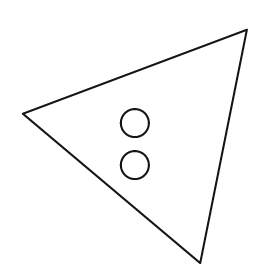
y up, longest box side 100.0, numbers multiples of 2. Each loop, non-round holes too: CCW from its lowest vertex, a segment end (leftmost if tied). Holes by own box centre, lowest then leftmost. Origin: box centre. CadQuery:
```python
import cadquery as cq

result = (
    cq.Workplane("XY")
    .moveTo(28.0, -50.0)
    .lineTo(48.0, 50.0)
    .lineTo(-48.0, 14.0)
    .close()
    .moveTo(0.0, -8.0)
    .circle(6.0)
    .moveTo(0.0, 10.0)
    .circle(6.0)
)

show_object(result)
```